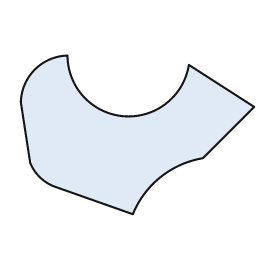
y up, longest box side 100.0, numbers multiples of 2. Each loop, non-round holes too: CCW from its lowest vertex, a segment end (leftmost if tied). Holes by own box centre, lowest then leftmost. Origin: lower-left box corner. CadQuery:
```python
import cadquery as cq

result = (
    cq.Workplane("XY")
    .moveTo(48.0, 0.0)
    .threePointArc((60.0, 16.0), (78.0, 24.0))
    .lineTo(100.0, 46.0)
    .lineTo(72.0, 64.0)
    .threePointArc((44.0, 42.0), (20.0, 68.0))
    .threePointArc((6.0, 62.0), (0.0, 48.0))
    .lineTo(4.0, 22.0)
    .threePointArc((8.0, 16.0), (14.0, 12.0))
    .close()
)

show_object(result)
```